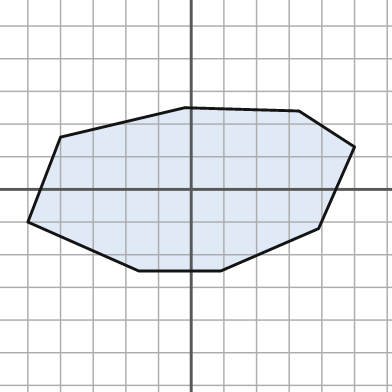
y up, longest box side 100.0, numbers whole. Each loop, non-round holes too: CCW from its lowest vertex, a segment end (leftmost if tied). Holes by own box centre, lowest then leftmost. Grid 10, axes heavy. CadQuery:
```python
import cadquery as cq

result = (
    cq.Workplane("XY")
    .moveTo(-16.0, -25.0)
    .lineTo(9.0, -25.0)
    .lineTo(39.0, -12.0)
    .lineTo(50.0, 13.0)
    .lineTo(33.0, 24.0)
    .lineTo(-2.0, 25.0)
    .lineTo(-40.0, 16.0)
    .lineTo(-50.0, -10.0)
    .close()
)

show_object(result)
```